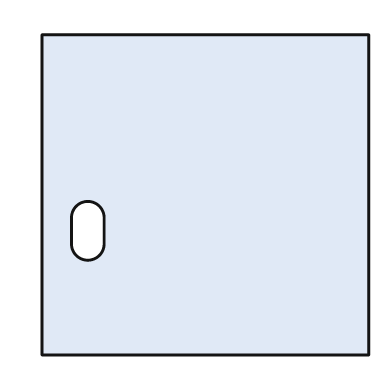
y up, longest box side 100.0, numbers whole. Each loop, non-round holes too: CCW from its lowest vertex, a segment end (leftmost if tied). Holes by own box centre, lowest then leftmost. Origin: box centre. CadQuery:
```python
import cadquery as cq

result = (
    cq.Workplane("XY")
    .moveTo(-50.0, -49.0)
    .lineTo(50.0, -49.0)
    .lineTo(50.0, 49.0)
    .lineTo(-50.0, 49.0)
    .close()
    .moveTo(-41.0, -15.0)
    .threePointArc((-36.0, -20.0), (-31.0, -15.0))
    .lineTo(-31.0, -7.0)
    .threePointArc((-36.0, -2.0), (-41.0, -7.0))
    .close()
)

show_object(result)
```